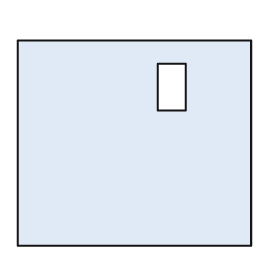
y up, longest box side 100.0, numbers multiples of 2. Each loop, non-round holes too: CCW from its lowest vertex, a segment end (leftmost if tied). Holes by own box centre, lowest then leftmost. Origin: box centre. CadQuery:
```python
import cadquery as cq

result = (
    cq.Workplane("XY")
    .moveTo(-50.0, -44.0)
    .lineTo(50.0, -44.0)
    .lineTo(50.0, 44.0)
    .lineTo(-50.0, 44.0)
    .close()
    .moveTo(10.0, 14.0)
    .lineTo(22.0, 14.0)
    .lineTo(22.0, 34.0)
    .lineTo(10.0, 34.0)
    .close()
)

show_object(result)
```